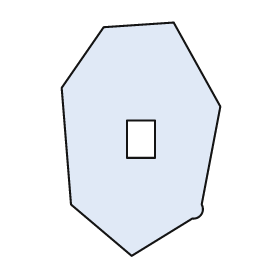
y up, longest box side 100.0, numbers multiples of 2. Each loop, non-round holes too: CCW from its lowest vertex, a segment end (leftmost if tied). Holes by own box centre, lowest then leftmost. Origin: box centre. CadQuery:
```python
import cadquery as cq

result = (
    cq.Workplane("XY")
    .moveTo(-4.0, -50.0)
    .lineTo(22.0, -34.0)
    .threePointArc((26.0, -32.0), (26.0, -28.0))
    .lineTo(34.0, 14.0)
    .lineTo(14.0, 50.0)
    .lineTo(-16.0, 48.0)
    .lineTo(-34.0, 22.0)
    .lineTo(-30.0, -28.0)
    .close()
    .moveTo(-6.0, -8.0)
    .lineTo(6.0, -8.0)
    .lineTo(6.0, 8.0)
    .lineTo(-6.0, 8.0)
    .close()
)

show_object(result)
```